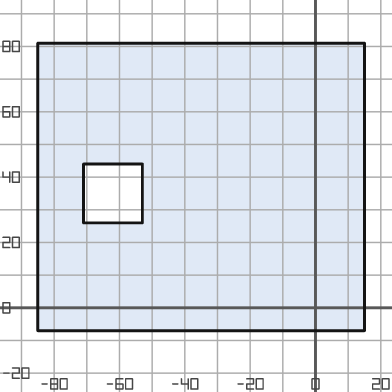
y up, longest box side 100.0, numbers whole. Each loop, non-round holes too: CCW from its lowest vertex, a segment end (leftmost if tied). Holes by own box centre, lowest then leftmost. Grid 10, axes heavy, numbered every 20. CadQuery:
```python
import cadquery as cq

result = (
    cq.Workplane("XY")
    .moveTo(-85.0, -7.0)
    .lineTo(15.0, -7.0)
    .lineTo(15.0, 81.0)
    .lineTo(-85.0, 81.0)
    .close()
    .moveTo(-71.0, 26.0)
    .lineTo(-53.0, 26.0)
    .lineTo(-53.0, 44.0)
    .lineTo(-71.0, 44.0)
    .close()
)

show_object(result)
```